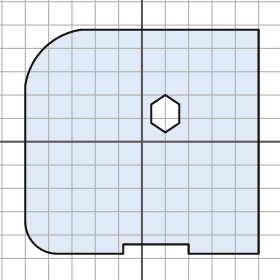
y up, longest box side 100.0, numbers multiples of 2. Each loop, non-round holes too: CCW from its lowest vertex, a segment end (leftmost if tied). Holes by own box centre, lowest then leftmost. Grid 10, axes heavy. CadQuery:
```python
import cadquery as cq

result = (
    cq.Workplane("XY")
    .moveTo(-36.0, -48.0)
    .lineTo(-8.0, -48.0)
    .lineTo(-8.0, -44.0)
    .lineTo(20.0, -44.0)
    .lineTo(20.0, -48.0)
    .lineTo(50.0, -48.0)
    .lineTo(50.0, 48.0)
    .lineTo(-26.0, 48.0)
    .threePointArc((-42.0, 40.0), (-50.0, 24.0))
    .lineTo(-50.0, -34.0)
    .threePointArc((-46.0, -44.0), (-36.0, -48.0))
    .close()
    .moveTo(10.0, 4.0)
    .lineTo(16.0, 8.0)
    .lineTo(16.0, 16.0)
    .lineTo(10.0, 20.0)
    .lineTo(4.0, 16.0)
    .lineTo(4.0, 8.0)
    .close()
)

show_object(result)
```